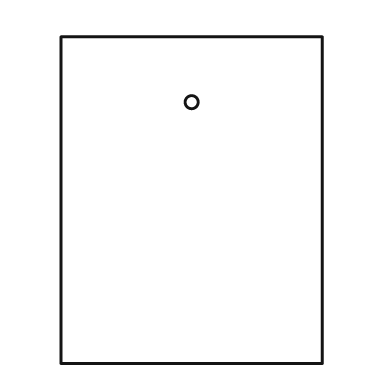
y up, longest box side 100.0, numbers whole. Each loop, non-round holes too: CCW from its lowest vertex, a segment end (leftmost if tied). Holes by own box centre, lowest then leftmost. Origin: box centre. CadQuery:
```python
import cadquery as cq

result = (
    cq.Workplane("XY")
    .moveTo(-40.0, -50.0)
    .lineTo(40.0, -50.0)
    .lineTo(40.0, 50.0)
    .lineTo(-40.0, 50.0)
    .close()
    .moveTo(0.0, 30.0)
    .circle(2.0)
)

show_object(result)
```